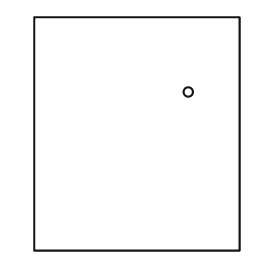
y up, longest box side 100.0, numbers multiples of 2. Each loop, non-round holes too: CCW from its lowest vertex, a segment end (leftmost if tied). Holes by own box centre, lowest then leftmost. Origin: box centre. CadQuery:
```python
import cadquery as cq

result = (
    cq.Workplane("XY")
    .moveTo(-44.0, -50.0)
    .lineTo(44.0, -50.0)
    .lineTo(44.0, 50.0)
    .lineTo(-44.0, 50.0)
    .close()
    .moveTo(22.0, 18.0)
    .circle(2.0)
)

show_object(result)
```